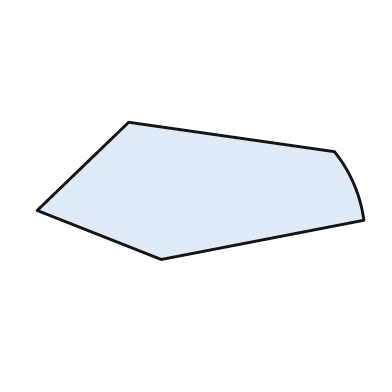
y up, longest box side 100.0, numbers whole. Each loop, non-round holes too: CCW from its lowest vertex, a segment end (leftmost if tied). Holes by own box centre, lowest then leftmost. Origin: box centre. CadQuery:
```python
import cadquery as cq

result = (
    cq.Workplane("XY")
    .moveTo(-12.0, -21.0)
    .lineTo(50.0, -9.0)
    .threePointArc((47.0, 2.0), (41.0, 12.0))
    .lineTo(-22.0, 21.0)
    .lineTo(-50.0, -6.0)
    .close()
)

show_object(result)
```